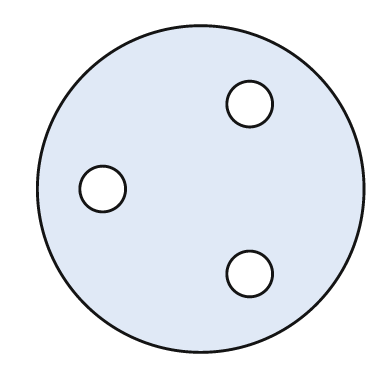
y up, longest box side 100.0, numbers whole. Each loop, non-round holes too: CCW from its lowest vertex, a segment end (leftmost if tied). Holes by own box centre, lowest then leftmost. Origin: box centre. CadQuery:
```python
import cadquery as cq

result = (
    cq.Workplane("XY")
    .moveTo(0.0, 0.0)
    .circle(50.0)
    .moveTo(15.0, -26.0)
    .circle(7.0)
    .moveTo(-30.0, 0.0)
    .circle(7.0)
    .moveTo(15.0, 26.0)
    .circle(7.0)
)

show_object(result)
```